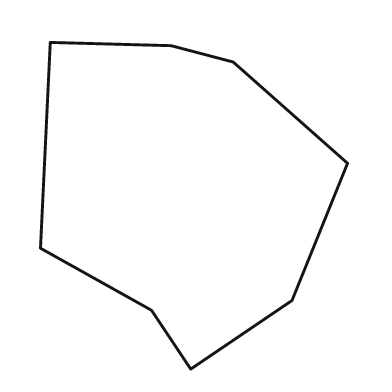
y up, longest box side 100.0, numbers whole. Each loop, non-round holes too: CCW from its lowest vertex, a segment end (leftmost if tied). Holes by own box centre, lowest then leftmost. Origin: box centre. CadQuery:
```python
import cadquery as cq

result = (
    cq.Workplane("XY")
    .moveTo(-1.0, -50.0)
    .lineTo(30.0, -29.0)
    .lineTo(47.0, 13.0)
    .lineTo(12.0, 44.0)
    .lineTo(-7.0, 49.0)
    .lineTo(-44.0, 50.0)
    .lineTo(-47.0, -13.0)
    .lineTo(-13.0, -32.0)
    .close()
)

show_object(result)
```